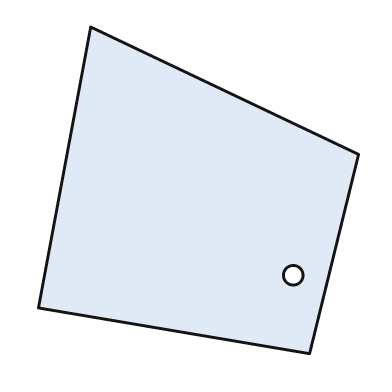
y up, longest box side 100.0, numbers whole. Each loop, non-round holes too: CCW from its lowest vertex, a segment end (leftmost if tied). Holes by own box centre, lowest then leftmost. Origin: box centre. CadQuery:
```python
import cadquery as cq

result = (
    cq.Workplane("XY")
    .moveTo(34.0, -50.0)
    .lineTo(49.0, 11.0)
    .lineTo(-33.0, 50.0)
    .lineTo(-49.0, -36.0)
    .close()
    .moveTo(29.0, -26.0)
    .circle(3.0)
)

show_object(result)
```